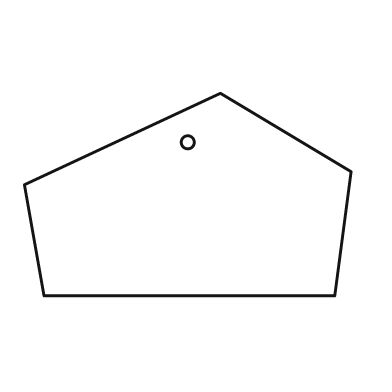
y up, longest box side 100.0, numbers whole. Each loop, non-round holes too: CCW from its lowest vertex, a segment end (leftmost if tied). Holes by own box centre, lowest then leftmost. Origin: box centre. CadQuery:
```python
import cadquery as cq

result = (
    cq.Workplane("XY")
    .moveTo(-44.0, -31.0)
    .lineTo(45.0, -31.0)
    .lineTo(50.0, 7.0)
    .lineTo(10.0, 31.0)
    .lineTo(-50.0, 3.0)
    .close()
    .moveTo(0.0, 16.0)
    .circle(2.0)
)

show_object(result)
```